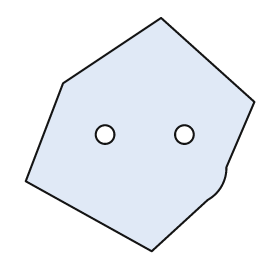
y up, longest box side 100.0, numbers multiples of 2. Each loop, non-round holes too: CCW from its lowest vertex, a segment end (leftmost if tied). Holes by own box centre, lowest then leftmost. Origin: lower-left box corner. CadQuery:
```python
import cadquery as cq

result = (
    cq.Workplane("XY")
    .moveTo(54.0, 0.0)
    .lineTo(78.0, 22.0)
    .threePointArc((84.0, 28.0), (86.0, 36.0))
    .lineTo(98.0, 64.0)
    .lineTo(58.0, 100.0)
    .lineTo(16.0, 72.0)
    .lineTo(0.0, 30.0)
    .close()
    .moveTo(34.0, 50.0)
    .circle(4.0)
    .moveTo(68.0, 50.0)
    .circle(4.0)
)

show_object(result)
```